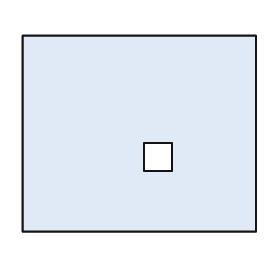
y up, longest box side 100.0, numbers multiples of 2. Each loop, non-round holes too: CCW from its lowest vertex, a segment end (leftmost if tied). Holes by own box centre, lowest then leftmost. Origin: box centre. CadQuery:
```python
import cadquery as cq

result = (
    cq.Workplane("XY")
    .moveTo(-50.0, -42.0)
    .lineTo(50.0, -42.0)
    .lineTo(50.0, 42.0)
    .lineTo(-50.0, 42.0)
    .close()
    .moveTo(2.0, -16.0)
    .lineTo(14.0, -16.0)
    .lineTo(14.0, -4.0)
    .lineTo(2.0, -4.0)
    .close()
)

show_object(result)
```